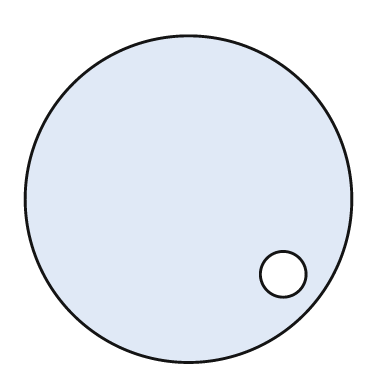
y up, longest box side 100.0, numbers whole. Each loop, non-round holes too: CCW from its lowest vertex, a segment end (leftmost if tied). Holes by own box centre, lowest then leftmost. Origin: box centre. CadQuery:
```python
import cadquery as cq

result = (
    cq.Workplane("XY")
    .moveTo(0.0, 0.0)
    .circle(50.0)
    .moveTo(29.0, -23.0)
    .circle(7.0)
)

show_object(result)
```